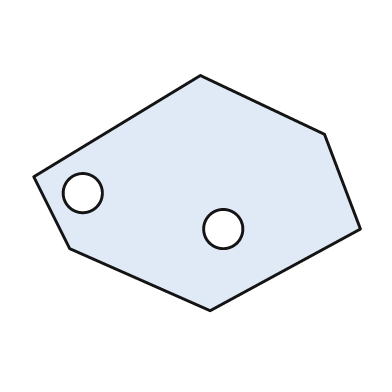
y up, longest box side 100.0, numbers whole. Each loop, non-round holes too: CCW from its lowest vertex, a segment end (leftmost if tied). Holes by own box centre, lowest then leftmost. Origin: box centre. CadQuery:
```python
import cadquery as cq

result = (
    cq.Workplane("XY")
    .moveTo(4.0, -36.0)
    .lineTo(50.0, -11.0)
    .lineTo(39.0, 18.0)
    .lineTo(1.0, 36.0)
    .lineTo(-50.0, 5.0)
    .lineTo(-39.0, -17.0)
    .close()
    .moveTo(8.0, -11.0)
    .circle(6.0)
    .moveTo(-35.0, 0.0)
    .circle(6.0)
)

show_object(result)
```